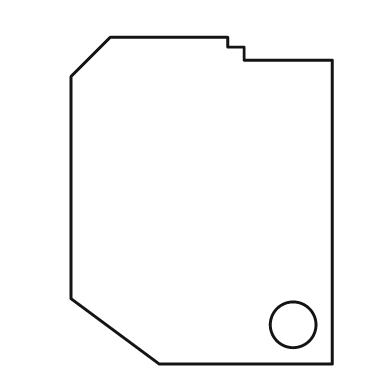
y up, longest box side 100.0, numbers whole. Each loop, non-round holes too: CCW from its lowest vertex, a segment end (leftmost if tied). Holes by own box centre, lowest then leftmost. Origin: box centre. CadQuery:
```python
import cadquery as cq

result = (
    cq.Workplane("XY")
    .moveTo(-13.0, -50.0)
    .lineTo(40.0, -50.0)
    .lineTo(40.0, 43.0)
    .lineTo(13.0, 43.0)
    .lineTo(13.0, 47.0)
    .lineTo(8.0, 47.0)
    .lineTo(8.0, 50.0)
    .lineTo(-28.0, 50.0)
    .lineTo(-40.0, 38.0)
    .lineTo(-40.0, -30.0)
    .close()
    .moveTo(28.0, -38.0)
    .circle(7.0)
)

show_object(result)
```